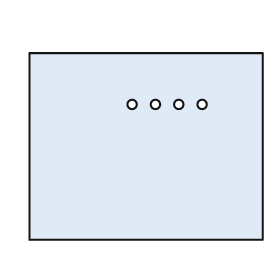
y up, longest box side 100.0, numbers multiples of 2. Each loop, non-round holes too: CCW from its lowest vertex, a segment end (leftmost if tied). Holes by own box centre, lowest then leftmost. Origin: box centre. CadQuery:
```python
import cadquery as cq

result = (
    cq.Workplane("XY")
    .moveTo(-50.0, -40.0)
    .lineTo(50.0, -40.0)
    .lineTo(50.0, 40.0)
    .lineTo(-50.0, 40.0)
    .close()
    .moveTo(-6.0, 18.0)
    .circle(2.0)
    .moveTo(4.0, 18.0)
    .circle(2.0)
    .moveTo(14.0, 18.0)
    .circle(2.0)
    .moveTo(24.0, 18.0)
    .circle(2.0)
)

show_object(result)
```